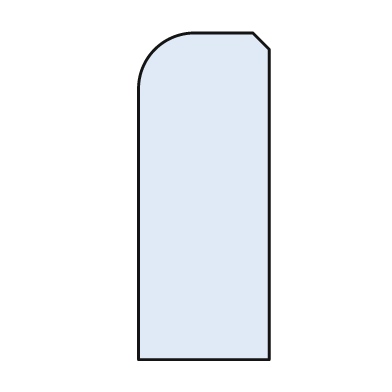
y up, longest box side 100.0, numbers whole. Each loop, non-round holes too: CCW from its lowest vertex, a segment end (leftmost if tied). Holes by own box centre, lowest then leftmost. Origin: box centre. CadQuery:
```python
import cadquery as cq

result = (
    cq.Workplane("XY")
    .moveTo(-20.0, -50.0)
    .lineTo(20.0, -50.0)
    .lineTo(20.0, 45.0)
    .lineTo(15.0, 50.0)
    .lineTo(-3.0, 50.0)
    .threePointArc((-15.0, 45.0), (-20.0, 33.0))
    .close()
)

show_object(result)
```